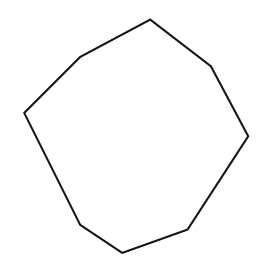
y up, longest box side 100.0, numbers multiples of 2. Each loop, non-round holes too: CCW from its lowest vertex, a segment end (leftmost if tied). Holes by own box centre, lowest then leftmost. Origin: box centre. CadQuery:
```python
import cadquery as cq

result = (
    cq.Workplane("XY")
    .moveTo(-6.0, -50.0)
    .lineTo(22.0, -40.0)
    .lineTo(48.0, 0.0)
    .lineTo(32.0, 30.0)
    .lineTo(6.0, 50.0)
    .lineTo(-24.0, 34.0)
    .lineTo(-48.0, 10.0)
    .lineTo(-24.0, -38.0)
    .close()
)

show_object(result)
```